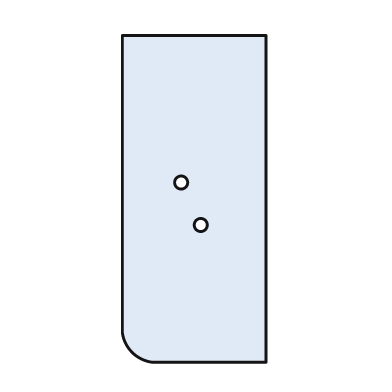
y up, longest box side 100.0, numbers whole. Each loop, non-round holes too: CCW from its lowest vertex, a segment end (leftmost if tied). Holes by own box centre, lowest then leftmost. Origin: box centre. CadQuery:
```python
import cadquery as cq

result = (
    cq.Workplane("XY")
    .moveTo(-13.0, -50.0)
    .lineTo(22.0, -50.0)
    .lineTo(22.0, 50.0)
    .lineTo(-22.0, 50.0)
    .lineTo(-22.0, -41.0)
    .threePointArc((-19.0, -47.0), (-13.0, -50.0))
    .close()
    .moveTo(2.0, -8.0)
    .circle(2.0)
    .moveTo(-4.0, 5.0)
    .circle(2.0)
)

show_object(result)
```